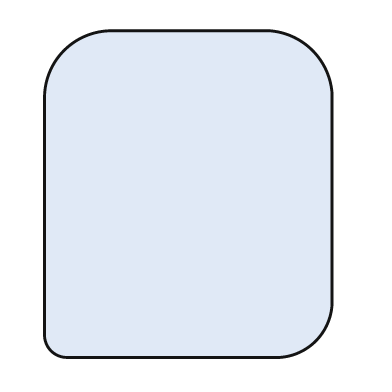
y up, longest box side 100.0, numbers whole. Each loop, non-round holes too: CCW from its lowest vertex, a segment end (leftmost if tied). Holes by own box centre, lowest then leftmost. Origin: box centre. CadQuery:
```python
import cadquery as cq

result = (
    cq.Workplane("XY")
    .moveTo(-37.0, -50.0)
    .lineTo(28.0, -50.0)
    .threePointArc((39.0, -45.0), (44.0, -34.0))
    .lineTo(44.0, 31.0)
    .threePointArc((38.0, 44.0), (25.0, 50.0))
    .lineTo(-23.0, 50.0)
    .threePointArc((-38.0, 44.0), (-44.0, 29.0))
    .lineTo(-44.0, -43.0)
    .threePointArc((-42.0, -48.0), (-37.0, -50.0))
    .close()
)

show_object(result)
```